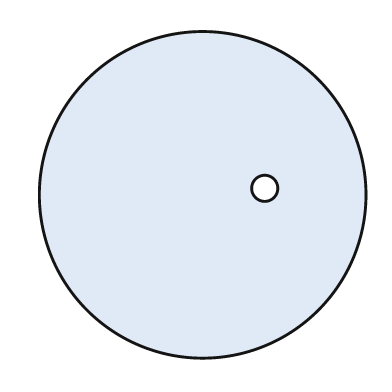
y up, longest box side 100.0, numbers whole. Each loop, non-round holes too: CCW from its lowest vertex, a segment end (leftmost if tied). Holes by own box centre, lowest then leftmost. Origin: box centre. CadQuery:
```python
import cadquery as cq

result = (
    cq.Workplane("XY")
    .moveTo(0.0, 0.0)
    .circle(50.0)
    .moveTo(19.0, 2.0)
    .circle(4.0)
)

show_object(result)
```